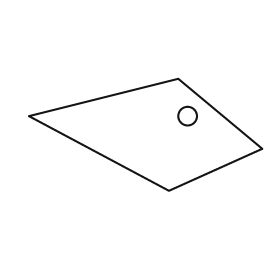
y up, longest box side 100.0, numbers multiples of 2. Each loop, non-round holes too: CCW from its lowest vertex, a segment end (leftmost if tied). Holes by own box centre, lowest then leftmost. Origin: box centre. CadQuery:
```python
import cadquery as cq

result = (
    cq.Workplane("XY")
    .moveTo(10.0, -24.0)
    .lineTo(50.0, -6.0)
    .lineTo(14.0, 24.0)
    .lineTo(-50.0, 8.0)
    .close()
    .moveTo(18.0, 8.0)
    .circle(4.0)
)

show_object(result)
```